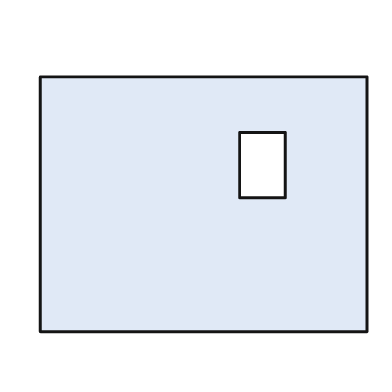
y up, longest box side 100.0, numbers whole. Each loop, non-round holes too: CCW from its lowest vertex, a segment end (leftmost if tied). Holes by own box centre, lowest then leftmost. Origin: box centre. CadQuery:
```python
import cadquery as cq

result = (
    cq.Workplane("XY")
    .moveTo(-50.0, -39.0)
    .lineTo(50.0, -39.0)
    .lineTo(50.0, 39.0)
    .lineTo(-50.0, 39.0)
    .close()
    .moveTo(11.0, 2.0)
    .lineTo(25.0, 2.0)
    .lineTo(25.0, 22.0)
    .lineTo(11.0, 22.0)
    .close()
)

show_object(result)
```